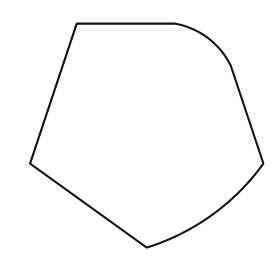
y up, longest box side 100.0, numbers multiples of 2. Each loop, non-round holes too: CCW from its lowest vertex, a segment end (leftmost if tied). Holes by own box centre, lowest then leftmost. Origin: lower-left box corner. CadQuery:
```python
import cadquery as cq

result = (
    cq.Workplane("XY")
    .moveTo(50.0, 0.0)
    .threePointArc((78.0, 14.0), (100.0, 36.0))
    .lineTo(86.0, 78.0)
    .threePointArc((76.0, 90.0), (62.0, 96.0))
    .lineTo(20.0, 96.0)
    .lineTo(0.0, 36.0)
    .close()
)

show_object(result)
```